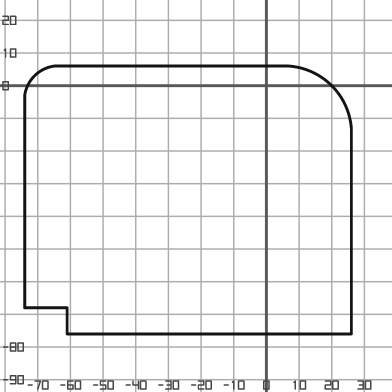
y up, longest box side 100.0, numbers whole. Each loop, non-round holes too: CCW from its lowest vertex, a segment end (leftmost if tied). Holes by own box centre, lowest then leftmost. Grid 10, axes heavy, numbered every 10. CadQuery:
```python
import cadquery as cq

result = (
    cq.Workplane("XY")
    .moveTo(-61.0, -76.0)
    .lineTo(26.0, -76.0)
    .lineTo(26.0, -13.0)
    .threePointArc((20.0, 0.0), (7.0, 6.0))
    .lineTo(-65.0, 6.0)
    .threePointArc((-71.0, 3.0), (-74.0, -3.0))
    .lineTo(-74.0, -68.0)
    .lineTo(-61.0, -68.0)
    .close()
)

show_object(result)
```